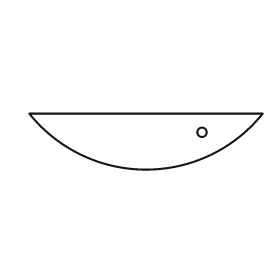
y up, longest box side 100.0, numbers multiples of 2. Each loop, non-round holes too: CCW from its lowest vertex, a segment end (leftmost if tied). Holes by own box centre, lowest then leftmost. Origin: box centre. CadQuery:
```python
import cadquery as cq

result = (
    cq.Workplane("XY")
    .moveTo(-50.0, 12.0)
    .threePointArc((0.0, -12.0), (50.0, 12.0))
    .close()
    .moveTo(24.0, 4.0)
    .circle(2.0)
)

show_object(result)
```